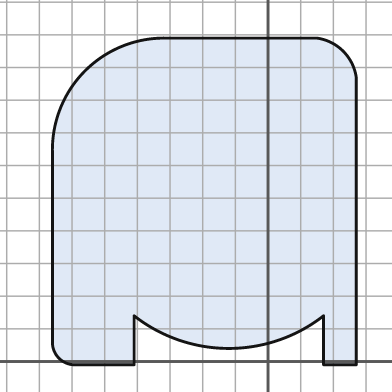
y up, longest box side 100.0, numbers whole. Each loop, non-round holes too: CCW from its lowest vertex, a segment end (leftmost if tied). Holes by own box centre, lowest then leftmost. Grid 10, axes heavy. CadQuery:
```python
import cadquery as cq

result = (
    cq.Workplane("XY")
    .moveTo(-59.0, -1.0)
    .lineTo(-41.0, -1.0)
    .lineTo(-41.0, 14.0)
    .threePointArc((-12.0, 4.0), (17.0, 14.0))
    .lineTo(17.0, -1.0)
    .lineTo(27.0, -1.0)
    .lineTo(27.0, 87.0)
    .threePointArc((23.0, 95.0), (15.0, 99.0))
    .lineTo(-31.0, 99.0)
    .threePointArc((-56.0, 89.0), (-66.0, 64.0))
    .lineTo(-66.0, 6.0)
    .threePointArc((-64.0, 1.0), (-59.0, -1.0))
    .close()
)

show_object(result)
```